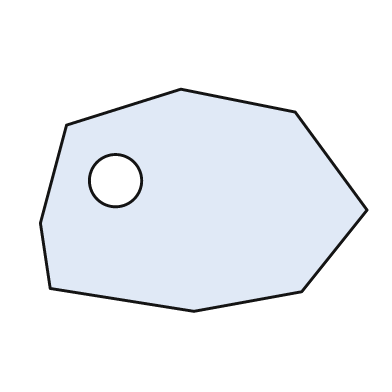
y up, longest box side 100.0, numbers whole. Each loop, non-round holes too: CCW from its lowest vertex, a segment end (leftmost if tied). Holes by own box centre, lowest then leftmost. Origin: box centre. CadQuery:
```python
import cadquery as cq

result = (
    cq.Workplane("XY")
    .moveTo(-3.0, -34.0)
    .lineTo(30.0, -28.0)
    .lineTo(50.0, -3.0)
    .lineTo(28.0, 27.0)
    .lineTo(-7.0, 34.0)
    .lineTo(-42.0, 23.0)
    .lineTo(-50.0, -7.0)
    .lineTo(-47.0, -27.0)
    .close()
    .moveTo(-27.0, 6.0)
    .circle(8.0)
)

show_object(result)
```